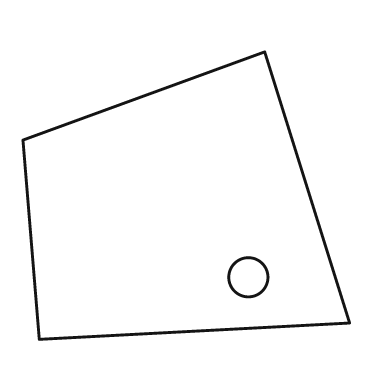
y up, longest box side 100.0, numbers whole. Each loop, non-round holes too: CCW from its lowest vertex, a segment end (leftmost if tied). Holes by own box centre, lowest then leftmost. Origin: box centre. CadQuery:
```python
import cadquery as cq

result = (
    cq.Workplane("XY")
    .moveTo(-45.0, -44.0)
    .lineTo(50.0, -39.0)
    .lineTo(24.0, 44.0)
    .lineTo(-50.0, 17.0)
    .close()
    .moveTo(19.0, -25.0)
    .circle(6.0)
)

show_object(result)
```